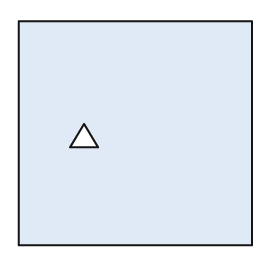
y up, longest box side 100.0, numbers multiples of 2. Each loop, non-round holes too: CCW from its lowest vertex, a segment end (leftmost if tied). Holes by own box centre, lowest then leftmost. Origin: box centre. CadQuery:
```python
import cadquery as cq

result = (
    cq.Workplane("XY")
    .moveTo(-50.0, -48.0)
    .lineTo(50.0, -48.0)
    .lineTo(50.0, 48.0)
    .lineTo(-50.0, 48.0)
    .close()
    .moveTo(-28.0, -6.0)
    .lineTo(-16.0, -6.0)
    .lineTo(-22.0, 4.0)
    .close()
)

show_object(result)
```